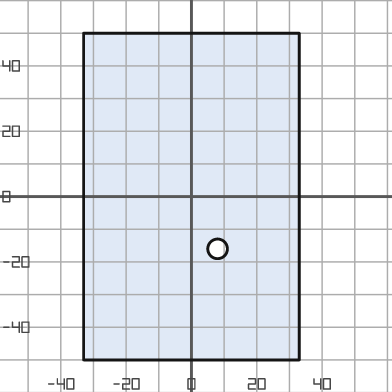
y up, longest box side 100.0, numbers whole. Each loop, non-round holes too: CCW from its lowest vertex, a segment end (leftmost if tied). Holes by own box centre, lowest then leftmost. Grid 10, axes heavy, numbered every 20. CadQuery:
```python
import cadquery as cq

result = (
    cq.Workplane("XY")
    .moveTo(-33.0, -50.0)
    .lineTo(33.0, -50.0)
    .lineTo(33.0, 50.0)
    .lineTo(-33.0, 50.0)
    .close()
    .moveTo(8.0, -16.0)
    .circle(3.0)
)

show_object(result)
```